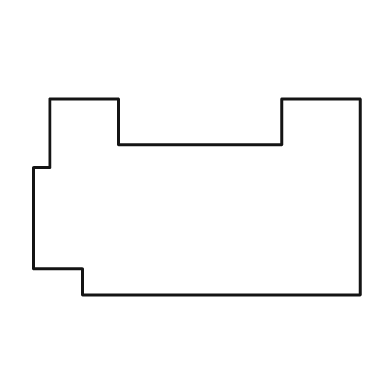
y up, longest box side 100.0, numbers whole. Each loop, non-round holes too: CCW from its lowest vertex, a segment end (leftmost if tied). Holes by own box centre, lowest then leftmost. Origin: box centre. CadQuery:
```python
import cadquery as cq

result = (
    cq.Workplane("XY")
    .moveTo(-35.0, -30.0)
    .lineTo(50.0, -30.0)
    .lineTo(50.0, 30.0)
    .lineTo(26.0, 30.0)
    .lineTo(26.0, 16.0)
    .lineTo(-24.0, 16.0)
    .lineTo(-24.0, 30.0)
    .lineTo(-45.0, 30.0)
    .lineTo(-45.0, 9.0)
    .lineTo(-50.0, 9.0)
    .lineTo(-50.0, -22.0)
    .lineTo(-35.0, -22.0)
    .close()
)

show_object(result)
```